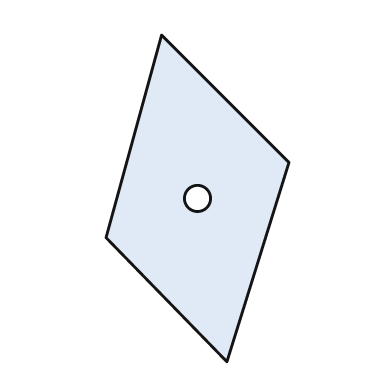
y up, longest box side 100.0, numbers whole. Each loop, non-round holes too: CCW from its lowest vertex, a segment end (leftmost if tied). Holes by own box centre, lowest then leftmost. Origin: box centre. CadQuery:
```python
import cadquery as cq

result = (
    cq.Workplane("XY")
    .moveTo(9.0, -50.0)
    .lineTo(28.0, 11.0)
    .lineTo(-11.0, 50.0)
    .lineTo(-28.0, -12.0)
    .close()
    .moveTo(0.0, 0.0)
    .circle(4.0)
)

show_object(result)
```